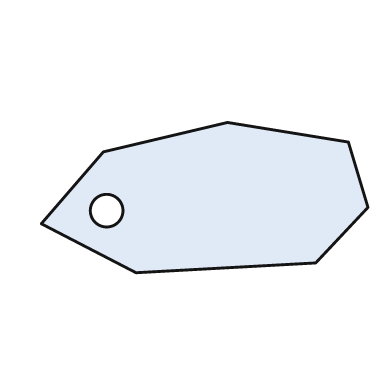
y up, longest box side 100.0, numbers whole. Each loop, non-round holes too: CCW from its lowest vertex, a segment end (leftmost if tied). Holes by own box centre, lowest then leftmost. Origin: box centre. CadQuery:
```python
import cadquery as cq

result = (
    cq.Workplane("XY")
    .moveTo(-21.0, -23.0)
    .lineTo(34.0, -20.0)
    .lineTo(50.0, -3.0)
    .lineTo(44.0, 17.0)
    .lineTo(7.0, 23.0)
    .lineTo(-31.0, 14.0)
    .lineTo(-50.0, -8.0)
    .close()
    .moveTo(-30.0, -4.0)
    .circle(5.0)
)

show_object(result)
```